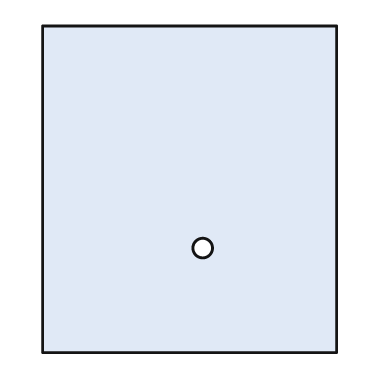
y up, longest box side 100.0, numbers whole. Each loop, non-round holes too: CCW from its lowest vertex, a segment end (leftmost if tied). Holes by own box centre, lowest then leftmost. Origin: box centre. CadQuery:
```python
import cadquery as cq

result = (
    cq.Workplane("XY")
    .moveTo(-45.0, -50.0)
    .lineTo(45.0, -50.0)
    .lineTo(45.0, 50.0)
    .lineTo(-45.0, 50.0)
    .close()
    .moveTo(4.0, -18.0)
    .circle(3.0)
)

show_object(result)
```